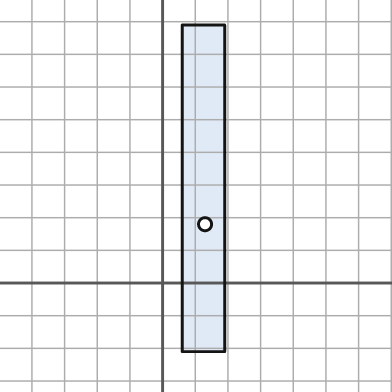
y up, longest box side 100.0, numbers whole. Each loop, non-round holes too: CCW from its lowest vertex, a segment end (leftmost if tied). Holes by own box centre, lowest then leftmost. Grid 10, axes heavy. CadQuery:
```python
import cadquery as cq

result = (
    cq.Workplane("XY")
    .moveTo(6.0, -21.0)
    .lineTo(19.0, -21.0)
    .lineTo(19.0, 79.0)
    .lineTo(6.0, 79.0)
    .close()
    .moveTo(13.0, 18.0)
    .circle(2.0)
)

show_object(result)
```